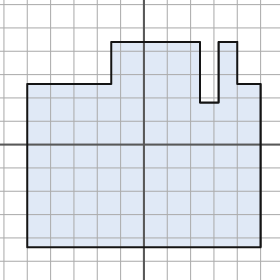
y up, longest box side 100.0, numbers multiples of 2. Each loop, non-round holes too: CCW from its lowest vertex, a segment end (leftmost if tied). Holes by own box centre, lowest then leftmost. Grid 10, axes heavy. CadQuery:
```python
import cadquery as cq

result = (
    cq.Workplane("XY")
    .moveTo(-50.0, -44.0)
    .lineTo(50.0, -44.0)
    .lineTo(50.0, 26.0)
    .lineTo(40.0, 26.0)
    .lineTo(40.0, 44.0)
    .lineTo(32.0, 44.0)
    .lineTo(32.0, 18.0)
    .lineTo(24.0, 18.0)
    .lineTo(24.0, 44.0)
    .lineTo(-14.0, 44.0)
    .lineTo(-14.0, 26.0)
    .lineTo(-50.0, 26.0)
    .close()
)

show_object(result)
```